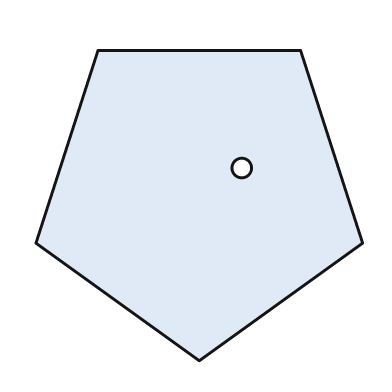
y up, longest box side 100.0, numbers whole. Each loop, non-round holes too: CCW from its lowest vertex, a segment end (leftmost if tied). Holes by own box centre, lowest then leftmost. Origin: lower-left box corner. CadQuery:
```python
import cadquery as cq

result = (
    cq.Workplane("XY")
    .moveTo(50.0, 0.0)
    .lineTo(100.0, 36.0)
    .lineTo(81.0, 95.0)
    .lineTo(19.0, 95.0)
    .lineTo(0.0, 36.0)
    .close()
    .moveTo(63.0, 59.0)
    .circle(3.0)
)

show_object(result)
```